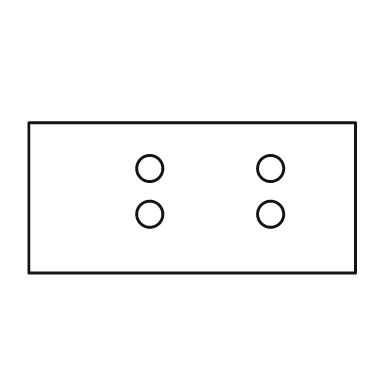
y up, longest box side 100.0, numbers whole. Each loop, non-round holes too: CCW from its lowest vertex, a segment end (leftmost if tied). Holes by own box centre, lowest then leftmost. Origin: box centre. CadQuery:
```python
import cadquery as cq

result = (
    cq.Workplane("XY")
    .moveTo(-50.0, -23.0)
    .lineTo(50.0, -23.0)
    .lineTo(50.0, 23.0)
    .lineTo(-50.0, 23.0)
    .close()
    .moveTo(-13.0, -5.0)
    .circle(4.0)
    .moveTo(24.0, -5.0)
    .circle(4.0)
    .moveTo(-13.0, 9.0)
    .circle(4.0)
    .moveTo(24.0, 9.0)
    .circle(4.0)
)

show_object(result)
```